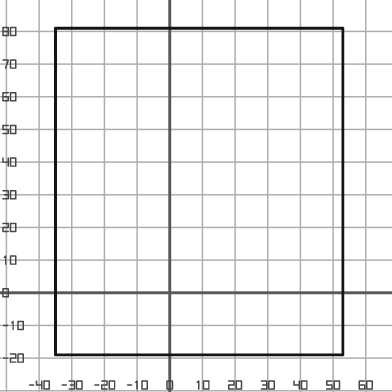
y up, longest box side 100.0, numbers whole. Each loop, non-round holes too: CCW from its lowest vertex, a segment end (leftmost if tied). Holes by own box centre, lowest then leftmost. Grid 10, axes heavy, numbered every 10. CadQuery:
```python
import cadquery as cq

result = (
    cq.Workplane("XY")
    .moveTo(-35.0, -19.0)
    .lineTo(53.0, -19.0)
    .lineTo(53.0, 81.0)
    .lineTo(-35.0, 81.0)
    .close()
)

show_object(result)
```